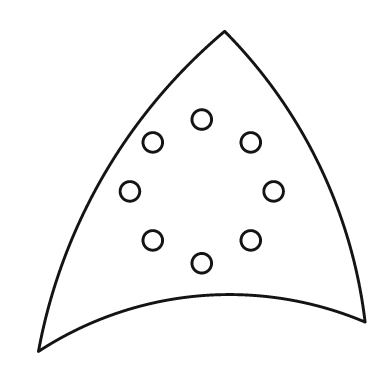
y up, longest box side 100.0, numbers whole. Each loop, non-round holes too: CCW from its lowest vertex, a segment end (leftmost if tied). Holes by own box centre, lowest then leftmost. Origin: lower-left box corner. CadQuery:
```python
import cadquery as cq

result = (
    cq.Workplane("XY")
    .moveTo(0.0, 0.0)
    .threePointArc((49.0, 17.0), (100.0, 9.0))
    .threePointArc((86.0, 57.0), (57.0, 98.0))
    .threePointArc((20.0, 54.0), (0.0, 0.0))
    .close()
    .moveTo(50.0, 27.0)
    .circle(3.0)
    .moveTo(35.0, 34.0)
    .circle(3.0)
    .moveTo(65.0, 34.0)
    .circle(3.0)
    .moveTo(28.0, 49.0)
    .circle(3.0)
    .moveTo(72.0, 49.0)
    .circle(3.0)
    .moveTo(35.0, 64.0)
    .circle(3.0)
    .moveTo(65.0, 64.0)
    .circle(3.0)
    .moveTo(50.0, 71.0)
    .circle(3.0)
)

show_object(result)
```